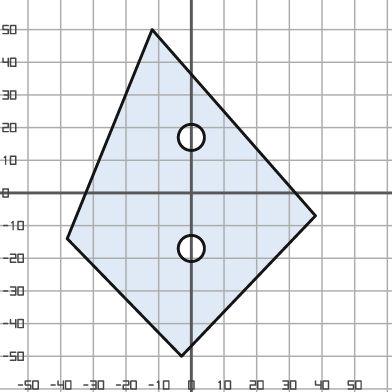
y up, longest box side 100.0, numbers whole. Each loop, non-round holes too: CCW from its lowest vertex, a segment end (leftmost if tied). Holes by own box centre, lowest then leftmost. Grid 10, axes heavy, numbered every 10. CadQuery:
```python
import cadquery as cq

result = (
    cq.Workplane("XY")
    .moveTo(-3.0, -50.0)
    .lineTo(38.0, -7.0)
    .lineTo(-12.0, 50.0)
    .lineTo(-38.0, -14.0)
    .close()
    .moveTo(0.0, -17.0)
    .circle(4.0)
    .moveTo(0.0, 17.0)
    .circle(4.0)
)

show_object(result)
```